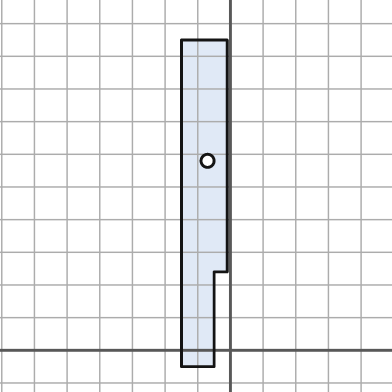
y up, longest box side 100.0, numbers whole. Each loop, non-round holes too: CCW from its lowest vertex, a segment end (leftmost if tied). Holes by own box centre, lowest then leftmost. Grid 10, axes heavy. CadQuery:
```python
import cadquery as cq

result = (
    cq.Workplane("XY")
    .moveTo(-15.0, -5.0)
    .lineTo(-5.0, -5.0)
    .lineTo(-5.0, 24.0)
    .lineTo(-1.0, 24.0)
    .lineTo(-1.0, 95.0)
    .lineTo(-15.0, 95.0)
    .close()
    .moveTo(-7.0, 58.0)
    .circle(2.0)
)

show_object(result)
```